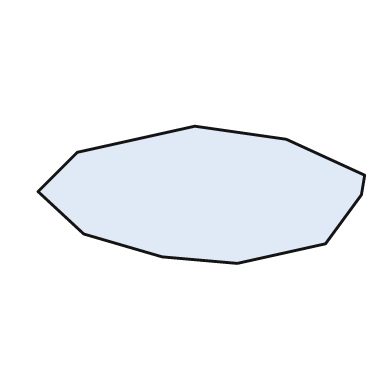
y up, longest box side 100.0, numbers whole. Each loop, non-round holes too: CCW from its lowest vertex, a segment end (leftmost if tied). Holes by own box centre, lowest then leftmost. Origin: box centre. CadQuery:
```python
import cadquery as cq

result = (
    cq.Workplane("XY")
    .moveTo(11.0, -21.0)
    .lineTo(38.0, -15.0)
    .lineTo(49.0, 0.0)
    .lineTo(50.0, 6.0)
    .lineTo(26.0, 17.0)
    .lineTo(-2.0, 21.0)
    .lineTo(-38.0, 13.0)
    .lineTo(-50.0, 1.0)
    .lineTo(-36.0, -12.0)
    .lineTo(-12.0, -19.0)
    .close()
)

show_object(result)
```